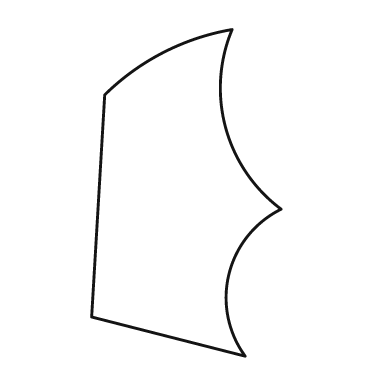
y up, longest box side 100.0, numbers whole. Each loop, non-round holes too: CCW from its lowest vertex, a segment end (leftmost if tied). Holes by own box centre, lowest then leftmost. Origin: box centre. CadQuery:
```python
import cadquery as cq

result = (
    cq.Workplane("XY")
    .moveTo(18.0, -50.0)
    .threePointArc((13.0, -25.0), (29.0, -5.0))
    .threePointArc((12.0, 20.0), (14.0, 50.0))
    .threePointArc((-7.0, 43.0), (-25.0, 30.0))
    .lineTo(-29.0, -38.0)
    .close()
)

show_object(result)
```